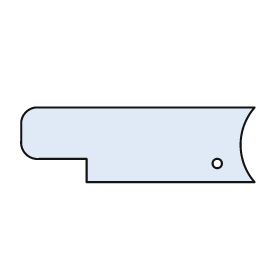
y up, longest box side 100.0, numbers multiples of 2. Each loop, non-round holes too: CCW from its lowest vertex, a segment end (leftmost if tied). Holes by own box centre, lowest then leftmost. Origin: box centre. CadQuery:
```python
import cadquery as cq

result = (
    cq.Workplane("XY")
    .moveTo(-22.0, -16.0)
    .lineTo(50.0, -16.0)
    .threePointArc((44.0, 0.0), (50.0, 16.0))
    .lineTo(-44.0, 16.0)
    .threePointArc((-48.0, 14.0), (-50.0, 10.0))
    .lineTo(-50.0, 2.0)
    .threePointArc((-48.0, -4.0), (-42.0, -6.0))
    .lineTo(-22.0, -6.0)
    .close()
    .moveTo(34.0, -8.0)
    .circle(2.0)
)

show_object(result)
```